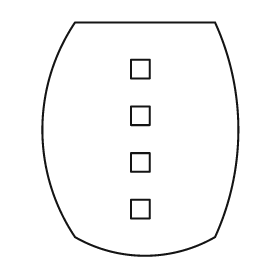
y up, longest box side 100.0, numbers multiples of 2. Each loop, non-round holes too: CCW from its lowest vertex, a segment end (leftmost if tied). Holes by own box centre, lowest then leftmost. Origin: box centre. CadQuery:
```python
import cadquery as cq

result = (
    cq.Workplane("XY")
    .moveTo(-28.0, -42.0)
    .threePointArc((2.0, -50.0), (32.0, -42.0))
    .threePointArc((42.0, 4.0), (32.0, 50.0))
    .lineTo(-28.0, 50.0)
    .threePointArc((-42.0, 4.0), (-28.0, -42.0))
    .close()
    .moveTo(-4.0, -34.0)
    .lineTo(4.0, -34.0)
    .lineTo(4.0, -26.0)
    .lineTo(-4.0, -26.0)
    .close()
    .moveTo(-4.0, -14.0)
    .lineTo(4.0, -14.0)
    .lineTo(4.0, -6.0)
    .lineTo(-4.0, -6.0)
    .close()
    .moveTo(-4.0, 6.0)
    .lineTo(4.0, 6.0)
    .lineTo(4.0, 14.0)
    .lineTo(-4.0, 14.0)
    .close()
    .moveTo(-4.0, 26.0)
    .lineTo(4.0, 26.0)
    .lineTo(4.0, 34.0)
    .lineTo(-4.0, 34.0)
    .close()
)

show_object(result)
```